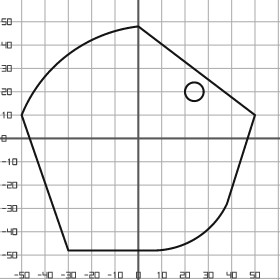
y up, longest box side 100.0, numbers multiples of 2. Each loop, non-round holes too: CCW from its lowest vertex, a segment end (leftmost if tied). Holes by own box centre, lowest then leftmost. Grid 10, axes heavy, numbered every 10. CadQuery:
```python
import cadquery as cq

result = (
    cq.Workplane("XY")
    .moveTo(-30.0, -48.0)
    .lineTo(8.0, -48.0)
    .threePointArc((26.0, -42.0), (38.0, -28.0))
    .lineTo(50.0, 10.0)
    .lineTo(0.0, 48.0)
    .threePointArc((-30.0, 36.0), (-50.0, 10.0))
    .close()
    .moveTo(24.0, 20.0)
    .circle(4.0)
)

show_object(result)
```